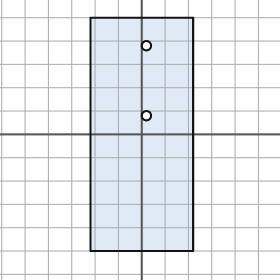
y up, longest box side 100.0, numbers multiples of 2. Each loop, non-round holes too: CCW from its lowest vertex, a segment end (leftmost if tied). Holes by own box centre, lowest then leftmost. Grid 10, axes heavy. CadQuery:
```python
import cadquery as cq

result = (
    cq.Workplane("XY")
    .moveTo(-22.0, -50.0)
    .lineTo(22.0, -50.0)
    .lineTo(22.0, 50.0)
    .lineTo(-22.0, 50.0)
    .close()
    .moveTo(2.0, 8.0)
    .circle(2.0)
    .moveTo(2.0, 38.0)
    .circle(2.0)
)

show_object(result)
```